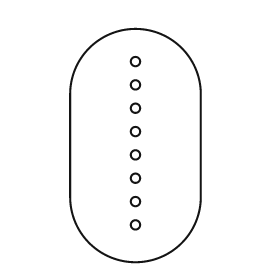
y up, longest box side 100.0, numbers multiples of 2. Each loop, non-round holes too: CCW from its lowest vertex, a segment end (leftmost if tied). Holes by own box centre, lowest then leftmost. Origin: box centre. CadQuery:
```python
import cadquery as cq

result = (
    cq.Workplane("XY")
    .moveTo(-28.0, -22.0)
    .threePointArc((0.0, -50.0), (28.0, -22.0))
    .lineTo(28.0, 22.0)
    .threePointArc((0.0, 50.0), (-28.0, 22.0))
    .close()
    .moveTo(0.0, -34.0)
    .circle(2.0)
    .moveTo(0.0, -24.0)
    .circle(2.0)
    .moveTo(0.0, -14.0)
    .circle(2.0)
    .moveTo(0.0, -4.0)
    .circle(2.0)
    .moveTo(0.0, 6.0)
    .circle(2.0)
    .moveTo(0.0, 16.0)
    .circle(2.0)
    .moveTo(0.0, 26.0)
    .circle(2.0)
    .moveTo(0.0, 36.0)
    .circle(2.0)
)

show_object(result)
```